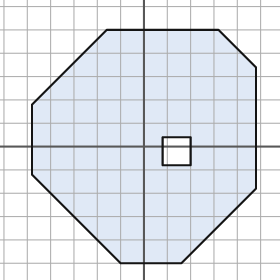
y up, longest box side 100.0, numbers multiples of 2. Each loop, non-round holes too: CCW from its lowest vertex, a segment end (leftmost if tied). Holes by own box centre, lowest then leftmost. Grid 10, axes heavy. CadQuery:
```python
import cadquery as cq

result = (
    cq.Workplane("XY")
    .moveTo(-10.0, -50.0)
    .lineTo(16.0, -50.0)
    .lineTo(48.0, -18.0)
    .lineTo(48.0, 34.0)
    .lineTo(32.0, 50.0)
    .lineTo(-16.0, 50.0)
    .lineTo(-48.0, 18.0)
    .lineTo(-48.0, -12.0)
    .close()
    .moveTo(8.0, -8.0)
    .lineTo(20.0, -8.0)
    .lineTo(20.0, 4.0)
    .lineTo(8.0, 4.0)
    .close()
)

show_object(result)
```